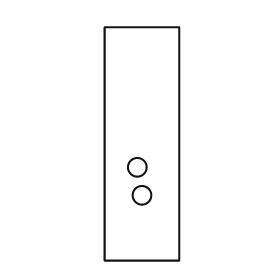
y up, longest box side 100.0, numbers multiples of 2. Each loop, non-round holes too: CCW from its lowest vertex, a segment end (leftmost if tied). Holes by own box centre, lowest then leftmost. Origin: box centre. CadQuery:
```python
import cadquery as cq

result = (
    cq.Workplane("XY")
    .moveTo(-16.0, -50.0)
    .lineTo(16.0, -50.0)
    .lineTo(16.0, 50.0)
    .lineTo(-16.0, 50.0)
    .close()
    .moveTo(0.0, -22.0)
    .circle(4.0)
    .moveTo(-2.0, -10.0)
    .circle(4.0)
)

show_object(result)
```